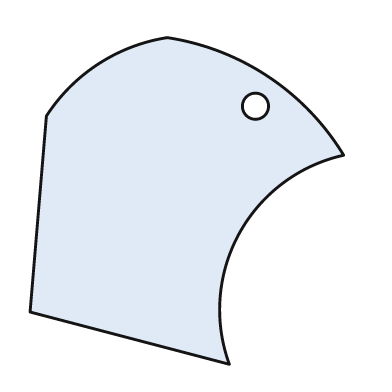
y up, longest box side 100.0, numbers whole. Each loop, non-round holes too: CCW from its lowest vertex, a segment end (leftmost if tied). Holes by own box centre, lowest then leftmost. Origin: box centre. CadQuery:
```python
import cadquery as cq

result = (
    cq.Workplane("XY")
    .moveTo(13.0, -50.0)
    .threePointArc((16.0, -10.0), (48.0, 14.0))
    .threePointArc((25.0, 38.0), (-6.0, 50.0))
    .threePointArc((-27.0, 42.0), (-43.0, 26.0))
    .lineTo(-48.0, -34.0)
    .close()
    .moveTo(21.0, 29.0)
    .circle(4.0)
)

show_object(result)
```